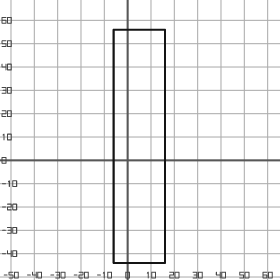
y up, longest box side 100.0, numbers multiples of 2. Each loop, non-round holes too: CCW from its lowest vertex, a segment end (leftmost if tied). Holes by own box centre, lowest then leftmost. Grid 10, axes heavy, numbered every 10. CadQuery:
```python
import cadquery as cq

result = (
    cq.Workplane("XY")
    .moveTo(-6.0, -44.0)
    .lineTo(16.0, -44.0)
    .lineTo(16.0, 56.0)
    .lineTo(-6.0, 56.0)
    .close()
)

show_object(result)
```